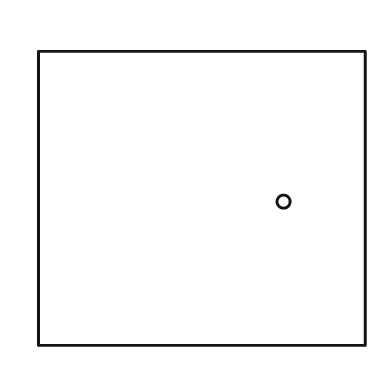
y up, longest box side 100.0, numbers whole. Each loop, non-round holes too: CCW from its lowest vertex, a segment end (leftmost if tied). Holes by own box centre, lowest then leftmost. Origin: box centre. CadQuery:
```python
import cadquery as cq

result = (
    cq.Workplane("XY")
    .moveTo(-50.0, -45.0)
    .lineTo(50.0, -45.0)
    .lineTo(50.0, 45.0)
    .lineTo(-50.0, 45.0)
    .close()
    .moveTo(25.0, -1.0)
    .circle(2.0)
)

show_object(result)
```